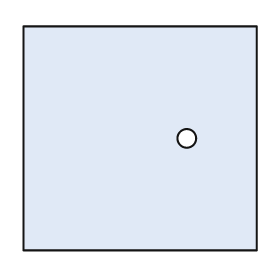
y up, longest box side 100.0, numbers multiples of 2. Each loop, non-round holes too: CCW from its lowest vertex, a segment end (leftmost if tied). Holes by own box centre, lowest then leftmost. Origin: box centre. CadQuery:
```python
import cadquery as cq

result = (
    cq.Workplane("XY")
    .moveTo(-50.0, -48.0)
    .lineTo(50.0, -48.0)
    .lineTo(50.0, 48.0)
    .lineTo(-50.0, 48.0)
    .close()
    .moveTo(20.0, 0.0)
    .circle(4.0)
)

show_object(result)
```